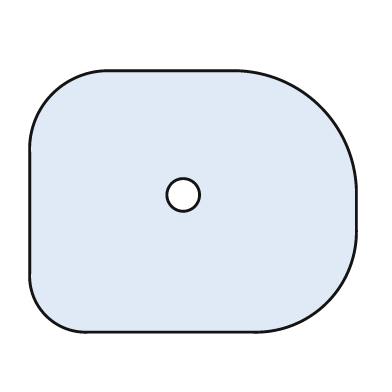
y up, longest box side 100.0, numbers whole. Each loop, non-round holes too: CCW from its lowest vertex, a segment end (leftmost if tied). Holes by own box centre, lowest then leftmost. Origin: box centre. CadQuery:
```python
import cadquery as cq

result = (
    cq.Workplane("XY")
    .moveTo(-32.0, -40.0)
    .lineTo(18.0, -40.0)
    .threePointArc((41.0, -31.0), (50.0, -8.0))
    .lineTo(50.0, 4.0)
    .threePointArc((39.0, 29.0), (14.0, 40.0))
    .lineTo(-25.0, 40.0)
    .threePointArc((-43.0, 33.0), (-50.0, 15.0))
    .lineTo(-50.0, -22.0)
    .threePointArc((-45.0, -35.0), (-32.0, -40.0))
    .close()
    .moveTo(-3.0, 2.0)
    .circle(5.0)
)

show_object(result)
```